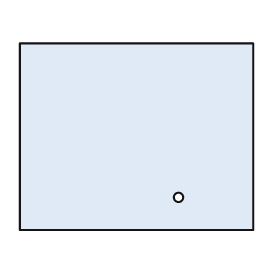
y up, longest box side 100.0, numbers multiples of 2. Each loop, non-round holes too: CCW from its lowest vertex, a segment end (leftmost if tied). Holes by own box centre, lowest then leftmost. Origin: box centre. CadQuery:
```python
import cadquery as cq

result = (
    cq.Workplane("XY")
    .moveTo(-50.0, -40.0)
    .lineTo(50.0, -40.0)
    .lineTo(50.0, 40.0)
    .lineTo(-50.0, 40.0)
    .close()
    .moveTo(18.0, -26.0)
    .circle(2.0)
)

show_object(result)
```